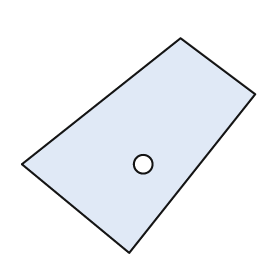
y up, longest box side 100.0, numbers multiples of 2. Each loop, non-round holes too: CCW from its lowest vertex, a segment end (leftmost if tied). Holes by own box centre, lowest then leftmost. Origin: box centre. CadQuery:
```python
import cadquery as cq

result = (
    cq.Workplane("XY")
    .moveTo(-4.0, -46.0)
    .lineTo(50.0, 22.0)
    .lineTo(18.0, 46.0)
    .lineTo(-50.0, -8.0)
    .close()
    .moveTo(2.0, -8.0)
    .circle(4.0)
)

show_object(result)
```